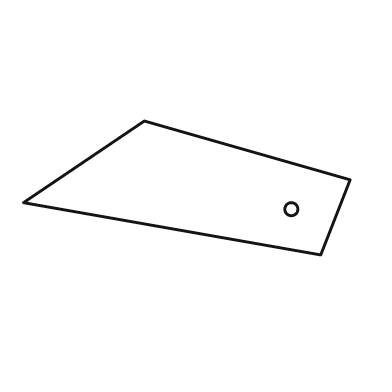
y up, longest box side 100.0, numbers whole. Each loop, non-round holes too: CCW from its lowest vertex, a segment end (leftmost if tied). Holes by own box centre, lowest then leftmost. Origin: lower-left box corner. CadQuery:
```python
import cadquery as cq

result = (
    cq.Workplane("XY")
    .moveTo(91.0, 0.0)
    .lineTo(100.0, 23.0)
    .lineTo(37.0, 41.0)
    .lineTo(0.0, 16.0)
    .close()
    .moveTo(82.0, 14.0)
    .circle(2.0)
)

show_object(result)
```